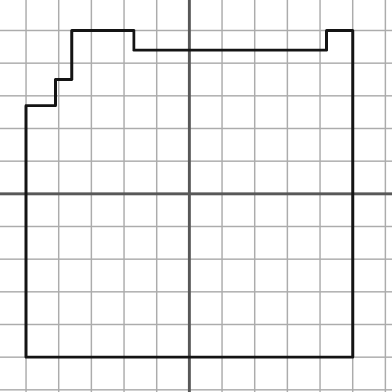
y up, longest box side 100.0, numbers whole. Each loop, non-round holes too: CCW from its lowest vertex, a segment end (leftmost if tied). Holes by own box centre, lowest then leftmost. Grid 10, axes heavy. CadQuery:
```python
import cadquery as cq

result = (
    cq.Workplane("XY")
    .moveTo(-50.0, -50.0)
    .lineTo(50.0, -50.0)
    .lineTo(50.0, 50.0)
    .lineTo(42.0, 50.0)
    .lineTo(42.0, 44.0)
    .lineTo(-17.0, 44.0)
    .lineTo(-17.0, 50.0)
    .lineTo(-36.0, 50.0)
    .lineTo(-36.0, 35.0)
    .lineTo(-41.0, 35.0)
    .lineTo(-41.0, 27.0)
    .lineTo(-50.0, 27.0)
    .close()
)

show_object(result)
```